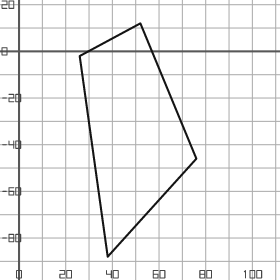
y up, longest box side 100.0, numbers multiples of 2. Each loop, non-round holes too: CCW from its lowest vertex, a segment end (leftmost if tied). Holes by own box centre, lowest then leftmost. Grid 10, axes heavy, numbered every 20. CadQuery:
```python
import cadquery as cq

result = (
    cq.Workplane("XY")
    .moveTo(38.0, -88.0)
    .lineTo(76.0, -46.0)
    .lineTo(52.0, 12.0)
    .lineTo(26.0, -2.0)
    .close()
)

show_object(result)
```